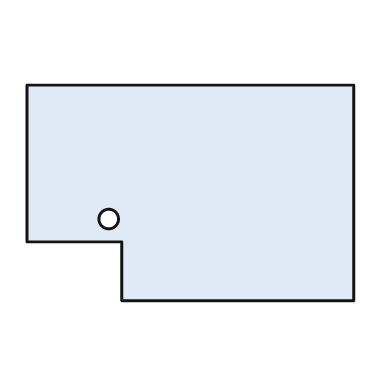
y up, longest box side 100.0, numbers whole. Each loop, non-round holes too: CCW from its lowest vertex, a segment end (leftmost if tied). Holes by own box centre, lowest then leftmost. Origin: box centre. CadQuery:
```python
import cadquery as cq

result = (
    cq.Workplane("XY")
    .moveTo(-21.0, -33.0)
    .lineTo(50.0, -33.0)
    .lineTo(50.0, 33.0)
    .lineTo(-50.0, 33.0)
    .lineTo(-50.0, -15.0)
    .lineTo(-21.0, -15.0)
    .close()
    .moveTo(-25.0, -8.0)
    .circle(3.0)
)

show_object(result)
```